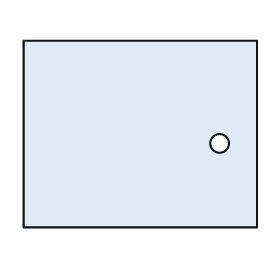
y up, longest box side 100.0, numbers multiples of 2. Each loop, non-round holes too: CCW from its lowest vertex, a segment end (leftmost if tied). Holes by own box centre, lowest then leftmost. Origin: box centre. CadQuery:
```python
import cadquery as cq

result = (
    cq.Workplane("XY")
    .moveTo(-50.0, -40.0)
    .lineTo(50.0, -40.0)
    .lineTo(50.0, 40.0)
    .lineTo(-50.0, 40.0)
    .close()
    .moveTo(34.0, -4.0)
    .circle(4.0)
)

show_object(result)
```